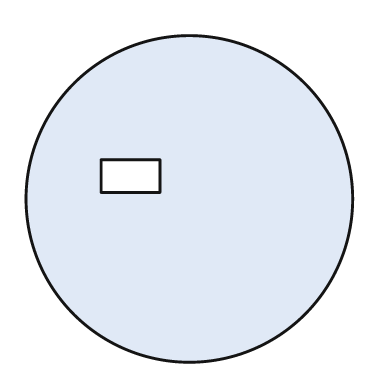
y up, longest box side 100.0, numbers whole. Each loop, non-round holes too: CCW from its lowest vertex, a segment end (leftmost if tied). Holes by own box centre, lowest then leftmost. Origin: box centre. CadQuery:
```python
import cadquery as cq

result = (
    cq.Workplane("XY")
    .moveTo(0.0, 0.0)
    .circle(50.0)
    .moveTo(-27.0, 2.0)
    .lineTo(-9.0, 2.0)
    .lineTo(-9.0, 12.0)
    .lineTo(-27.0, 12.0)
    .close()
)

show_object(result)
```